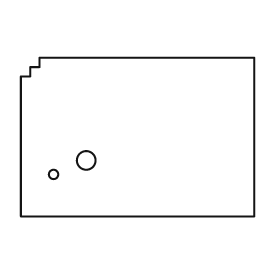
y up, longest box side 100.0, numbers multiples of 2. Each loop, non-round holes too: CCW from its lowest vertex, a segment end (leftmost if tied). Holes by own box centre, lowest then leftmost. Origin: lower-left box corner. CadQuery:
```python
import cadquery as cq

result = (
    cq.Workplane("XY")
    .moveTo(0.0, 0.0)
    .lineTo(100.0, 0.0)
    .lineTo(100.0, 68.0)
    .lineTo(8.0, 68.0)
    .lineTo(8.0, 64.0)
    .lineTo(4.0, 64.0)
    .lineTo(4.0, 60.0)
    .lineTo(0.0, 60.0)
    .close()
    .moveTo(14.0, 18.0)
    .circle(2.0)
    .moveTo(28.0, 24.0)
    .circle(4.0)
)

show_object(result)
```